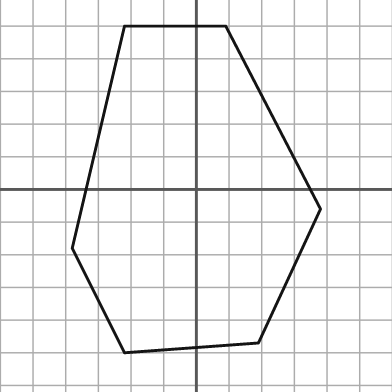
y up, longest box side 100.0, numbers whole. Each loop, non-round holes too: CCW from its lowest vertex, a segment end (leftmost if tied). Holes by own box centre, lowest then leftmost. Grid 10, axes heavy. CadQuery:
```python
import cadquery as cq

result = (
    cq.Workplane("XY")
    .moveTo(-22.0, -50.0)
    .lineTo(19.0, -47.0)
    .lineTo(38.0, -6.0)
    .lineTo(9.0, 50.0)
    .lineTo(-22.0, 50.0)
    .lineTo(-38.0, -18.0)
    .close()
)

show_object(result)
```